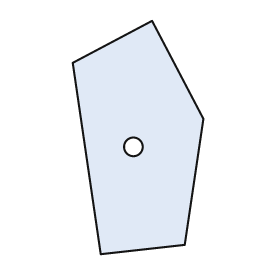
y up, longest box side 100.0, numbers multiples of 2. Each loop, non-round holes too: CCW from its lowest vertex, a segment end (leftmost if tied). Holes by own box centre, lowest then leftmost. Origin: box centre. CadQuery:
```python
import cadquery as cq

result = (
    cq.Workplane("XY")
    .moveTo(-16.0, -50.0)
    .lineTo(20.0, -46.0)
    .lineTo(28.0, 8.0)
    .lineTo(6.0, 50.0)
    .lineTo(-28.0, 32.0)
    .close()
    .moveTo(-2.0, -4.0)
    .circle(4.0)
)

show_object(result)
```